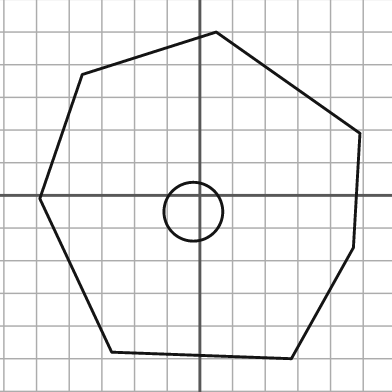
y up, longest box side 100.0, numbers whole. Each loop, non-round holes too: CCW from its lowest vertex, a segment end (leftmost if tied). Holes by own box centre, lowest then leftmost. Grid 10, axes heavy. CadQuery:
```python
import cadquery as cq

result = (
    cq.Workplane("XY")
    .moveTo(28.0, -50.0)
    .lineTo(47.0, -16.0)
    .lineTo(49.0, 19.0)
    .lineTo(5.0, 50.0)
    .lineTo(-36.0, 37.0)
    .lineTo(-49.0, -1.0)
    .lineTo(-27.0, -48.0)
    .close()
    .moveTo(-2.0, -5.0)
    .circle(9.0)
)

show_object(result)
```